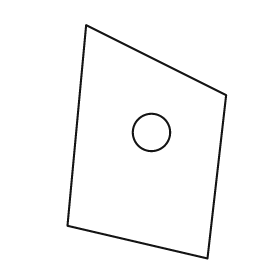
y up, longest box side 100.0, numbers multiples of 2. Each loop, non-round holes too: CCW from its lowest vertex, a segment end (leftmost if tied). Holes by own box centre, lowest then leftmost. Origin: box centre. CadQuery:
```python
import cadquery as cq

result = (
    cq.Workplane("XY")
    .moveTo(26.0, -50.0)
    .lineTo(34.0, 20.0)
    .lineTo(-26.0, 50.0)
    .lineTo(-34.0, -36.0)
    .close()
    .moveTo(2.0, 4.0)
    .circle(8.0)
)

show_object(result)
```